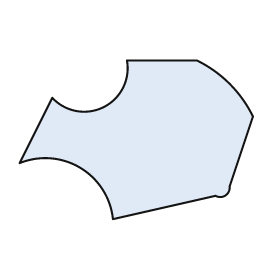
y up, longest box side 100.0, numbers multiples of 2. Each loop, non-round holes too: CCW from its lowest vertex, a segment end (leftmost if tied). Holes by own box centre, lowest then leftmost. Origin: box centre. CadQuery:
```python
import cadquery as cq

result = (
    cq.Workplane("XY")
    .moveTo(-10.0, -34.0)
    .lineTo(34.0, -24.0)
    .threePointArc((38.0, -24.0), (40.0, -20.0))
    .lineTo(50.0, 10.0)
    .threePointArc((40.0, 24.0), (26.0, 34.0))
    .lineTo(-4.0, 34.0)
    .threePointArc((-14.0, 14.0), (-36.0, 18.0))
    .lineTo(-50.0, -10.0)
    .threePointArc((-24.0, -12.0), (-10.0, -34.0))
    .close()
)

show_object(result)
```